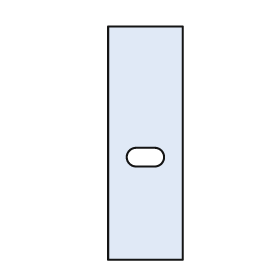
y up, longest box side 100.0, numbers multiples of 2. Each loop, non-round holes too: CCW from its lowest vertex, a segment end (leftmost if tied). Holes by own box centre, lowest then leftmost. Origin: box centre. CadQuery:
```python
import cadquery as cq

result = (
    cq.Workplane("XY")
    .moveTo(-16.0, -50.0)
    .lineTo(16.0, -50.0)
    .lineTo(16.0, 50.0)
    .lineTo(-16.0, 50.0)
    .close()
    .moveTo(-4.0, -10.0)
    .lineTo(4.0, -10.0)
    .threePointArc((8.0, -6.0), (4.0, -2.0))
    .lineTo(-4.0, -2.0)
    .threePointArc((-8.0, -6.0), (-4.0, -10.0))
    .close()
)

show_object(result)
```